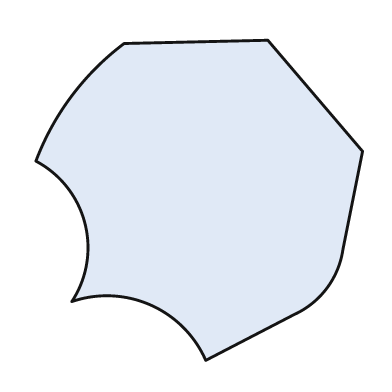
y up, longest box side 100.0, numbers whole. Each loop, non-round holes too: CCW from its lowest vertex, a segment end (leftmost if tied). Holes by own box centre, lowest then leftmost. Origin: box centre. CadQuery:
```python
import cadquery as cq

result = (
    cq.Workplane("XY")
    .moveTo(2.0, -49.0)
    .lineTo(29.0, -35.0)
    .threePointArc((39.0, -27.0), (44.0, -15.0))
    .lineTo(50.0, 15.0)
    .lineTo(21.0, 49.0)
    .lineTo(-23.0, 48.0)
    .threePointArc((-39.0, 32.0), (-50.0, 12.0))
    .threePointArc((-35.0, -7.0), (-39.0, -31.0))
    .threePointArc((-15.0, -32.0), (2.0, -49.0))
    .close()
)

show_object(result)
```